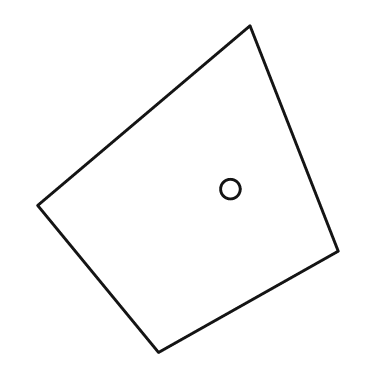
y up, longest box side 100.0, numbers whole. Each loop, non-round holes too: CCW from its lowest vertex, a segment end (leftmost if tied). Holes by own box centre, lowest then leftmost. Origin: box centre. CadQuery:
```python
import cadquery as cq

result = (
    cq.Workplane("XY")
    .moveTo(-9.0, -50.0)
    .lineTo(46.0, -19.0)
    .lineTo(19.0, 50.0)
    .lineTo(-46.0, -5.0)
    .close()
    .moveTo(13.0, 0.0)
    .circle(3.0)
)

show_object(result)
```